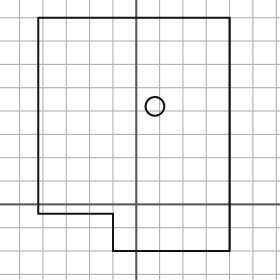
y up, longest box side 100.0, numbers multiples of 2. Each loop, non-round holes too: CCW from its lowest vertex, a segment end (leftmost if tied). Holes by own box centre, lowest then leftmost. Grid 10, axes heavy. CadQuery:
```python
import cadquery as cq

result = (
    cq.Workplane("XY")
    .moveTo(-10.0, -20.0)
    .lineTo(40.0, -20.0)
    .lineTo(40.0, 80.0)
    .lineTo(-42.0, 80.0)
    .lineTo(-42.0, -4.0)
    .lineTo(-10.0, -4.0)
    .close()
    .moveTo(8.0, 42.0)
    .circle(4.0)
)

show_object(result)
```